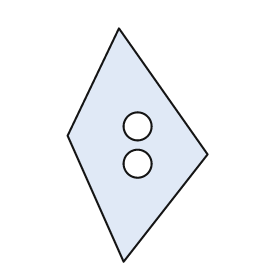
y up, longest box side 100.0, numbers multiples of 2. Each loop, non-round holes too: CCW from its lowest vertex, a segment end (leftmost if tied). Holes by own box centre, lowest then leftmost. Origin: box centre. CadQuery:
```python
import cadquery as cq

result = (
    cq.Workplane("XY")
    .moveTo(-6.0, -50.0)
    .lineTo(30.0, -4.0)
    .lineTo(-8.0, 50.0)
    .lineTo(-30.0, 4.0)
    .close()
    .moveTo(0.0, -8.0)
    .circle(6.0)
    .moveTo(0.0, 8.0)
    .circle(6.0)
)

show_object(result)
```